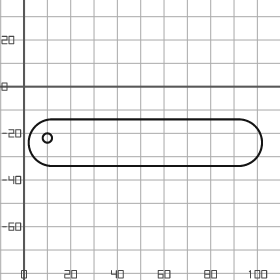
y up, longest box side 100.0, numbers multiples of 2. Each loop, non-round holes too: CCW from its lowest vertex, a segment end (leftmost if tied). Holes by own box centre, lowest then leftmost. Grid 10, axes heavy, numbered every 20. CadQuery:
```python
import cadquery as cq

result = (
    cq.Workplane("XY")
    .moveTo(12.0, -34.0)
    .lineTo(92.0, -34.0)
    .threePointArc((102.0, -24.0), (92.0, -14.0))
    .lineTo(12.0, -14.0)
    .threePointArc((2.0, -24.0), (12.0, -34.0))
    .close()
    .moveTo(10.0, -22.0)
    .circle(2.0)
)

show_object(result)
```